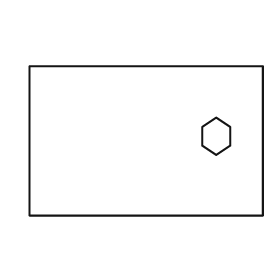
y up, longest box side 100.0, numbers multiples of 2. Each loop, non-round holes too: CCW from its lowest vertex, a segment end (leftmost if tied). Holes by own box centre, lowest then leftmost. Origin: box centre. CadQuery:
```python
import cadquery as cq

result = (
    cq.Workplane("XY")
    .moveTo(-50.0, -32.0)
    .lineTo(50.0, -32.0)
    .lineTo(50.0, 32.0)
    .lineTo(-50.0, 32.0)
    .close()
    .moveTo(30.0, -6.0)
    .lineTo(36.0, -2.0)
    .lineTo(36.0, 6.0)
    .lineTo(30.0, 10.0)
    .lineTo(24.0, 6.0)
    .lineTo(24.0, -2.0)
    .close()
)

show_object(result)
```